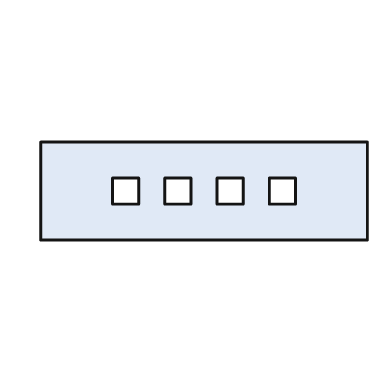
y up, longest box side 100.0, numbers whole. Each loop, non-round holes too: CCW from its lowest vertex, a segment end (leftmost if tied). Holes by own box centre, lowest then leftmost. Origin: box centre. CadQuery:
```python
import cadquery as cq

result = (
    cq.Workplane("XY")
    .moveTo(-50.0, -15.0)
    .lineTo(50.0, -15.0)
    .lineTo(50.0, 15.0)
    .lineTo(-50.0, 15.0)
    .close()
    .moveTo(-28.0, -4.0)
    .lineTo(-20.0, -4.0)
    .lineTo(-20.0, 4.0)
    .lineTo(-28.0, 4.0)
    .close()
    .moveTo(-12.0, -4.0)
    .lineTo(-4.0, -4.0)
    .lineTo(-4.0, 4.0)
    .lineTo(-12.0, 4.0)
    .close()
    .moveTo(4.0, -4.0)
    .lineTo(12.0, -4.0)
    .lineTo(12.0, 4.0)
    .lineTo(4.0, 4.0)
    .close()
    .moveTo(20.0, -4.0)
    .lineTo(28.0, -4.0)
    .lineTo(28.0, 4.0)
    .lineTo(20.0, 4.0)
    .close()
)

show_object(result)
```